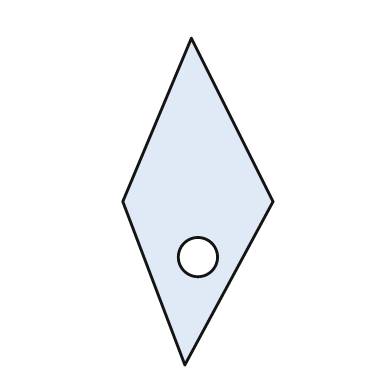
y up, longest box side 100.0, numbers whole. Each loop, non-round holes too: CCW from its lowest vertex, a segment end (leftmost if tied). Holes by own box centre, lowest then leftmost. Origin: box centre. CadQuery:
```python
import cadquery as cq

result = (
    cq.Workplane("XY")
    .moveTo(-4.0, -50.0)
    .lineTo(23.0, 0.0)
    .lineTo(-2.0, 50.0)
    .lineTo(-23.0, 0.0)
    .close()
    .moveTo(0.0, -17.0)
    .circle(6.0)
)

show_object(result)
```